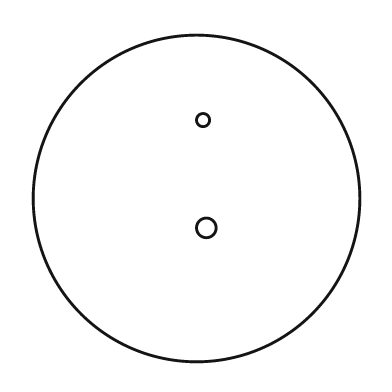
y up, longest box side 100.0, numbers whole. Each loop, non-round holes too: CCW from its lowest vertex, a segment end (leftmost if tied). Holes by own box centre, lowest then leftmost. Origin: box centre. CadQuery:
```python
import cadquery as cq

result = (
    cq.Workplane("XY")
    .moveTo(0.0, 0.0)
    .circle(50.0)
    .moveTo(3.0, -9.0)
    .circle(3.0)
    .moveTo(2.0, 24.0)
    .circle(2.0)
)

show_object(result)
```